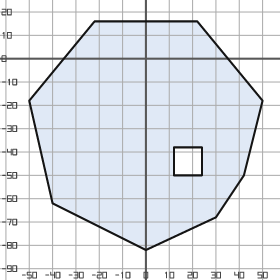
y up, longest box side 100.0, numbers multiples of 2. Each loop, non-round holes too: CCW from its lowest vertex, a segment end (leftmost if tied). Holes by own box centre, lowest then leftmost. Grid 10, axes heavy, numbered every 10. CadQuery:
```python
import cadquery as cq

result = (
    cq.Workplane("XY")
    .moveTo(0.0, -82.0)
    .lineTo(30.0, -68.0)
    .lineTo(42.0, -50.0)
    .lineTo(50.0, -18.0)
    .lineTo(22.0, 16.0)
    .lineTo(-22.0, 16.0)
    .lineTo(-50.0, -18.0)
    .lineTo(-40.0, -62.0)
    .close()
    .moveTo(12.0, -50.0)
    .lineTo(24.0, -50.0)
    .lineTo(24.0, -38.0)
    .lineTo(12.0, -38.0)
    .close()
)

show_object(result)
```